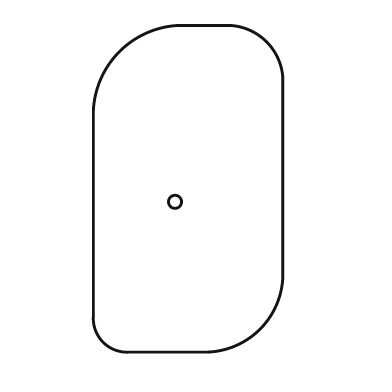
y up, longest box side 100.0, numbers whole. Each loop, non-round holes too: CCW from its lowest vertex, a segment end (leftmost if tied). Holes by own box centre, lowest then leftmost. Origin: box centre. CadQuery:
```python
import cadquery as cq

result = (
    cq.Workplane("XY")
    .moveTo(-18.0, -50.0)
    .lineTo(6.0, -50.0)
    .threePointArc((22.0, -43.0), (29.0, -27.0))
    .lineTo(29.0, 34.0)
    .threePointArc((24.0, 45.0), (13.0, 50.0))
    .lineTo(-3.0, 50.0)
    .threePointArc((-21.0, 42.0), (-29.0, 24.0))
    .lineTo(-29.0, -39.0)
    .threePointArc((-26.0, -47.0), (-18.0, -50.0))
    .close()
    .moveTo(-4.0, -4.0)
    .circle(2.0)
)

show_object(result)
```